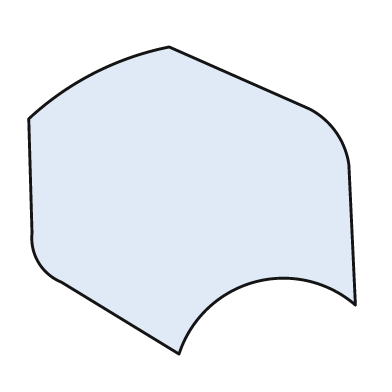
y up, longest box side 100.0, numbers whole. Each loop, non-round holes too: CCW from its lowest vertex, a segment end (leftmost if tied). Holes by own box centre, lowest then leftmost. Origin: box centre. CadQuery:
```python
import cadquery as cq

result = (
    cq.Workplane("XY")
    .moveTo(-4.0, -47.0)
    .threePointArc((19.0, -25.0), (50.0, -32.0))
    .lineTo(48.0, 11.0)
    .threePointArc((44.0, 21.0), (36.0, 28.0))
    .lineTo(-7.0, 47.0)
    .threePointArc((-30.0, 39.0), (-50.0, 25.0))
    .lineTo(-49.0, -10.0)
    .threePointArc((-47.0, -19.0), (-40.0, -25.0))
    .close()
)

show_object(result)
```